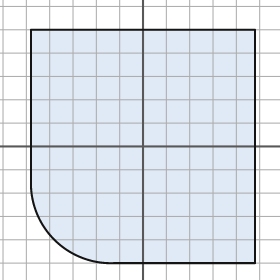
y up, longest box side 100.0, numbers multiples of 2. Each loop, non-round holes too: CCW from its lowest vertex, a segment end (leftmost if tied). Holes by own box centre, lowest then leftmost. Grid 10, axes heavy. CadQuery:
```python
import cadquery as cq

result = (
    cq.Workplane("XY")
    .moveTo(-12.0, -50.0)
    .lineTo(48.0, -50.0)
    .lineTo(48.0, 50.0)
    .lineTo(-48.0, 50.0)
    .lineTo(-48.0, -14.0)
    .threePointArc((-38.0, -40.0), (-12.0, -50.0))
    .close()
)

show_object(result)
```